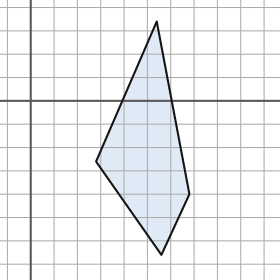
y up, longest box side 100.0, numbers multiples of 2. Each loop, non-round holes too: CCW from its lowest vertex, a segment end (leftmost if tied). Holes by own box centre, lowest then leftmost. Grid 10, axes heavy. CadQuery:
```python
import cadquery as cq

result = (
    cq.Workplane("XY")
    .moveTo(56.0, -66.0)
    .lineTo(68.0, -40.0)
    .lineTo(54.0, 34.0)
    .lineTo(28.0, -26.0)
    .close()
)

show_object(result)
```